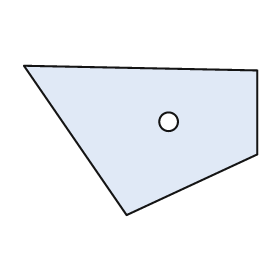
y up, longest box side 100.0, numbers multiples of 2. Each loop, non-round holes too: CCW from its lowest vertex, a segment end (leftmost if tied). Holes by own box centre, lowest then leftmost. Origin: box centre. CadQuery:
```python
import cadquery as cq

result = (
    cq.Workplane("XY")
    .moveTo(-6.0, -32.0)
    .lineTo(50.0, -6.0)
    .lineTo(50.0, 30.0)
    .lineTo(-50.0, 32.0)
    .close()
    .moveTo(12.0, 8.0)
    .circle(4.0)
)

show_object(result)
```